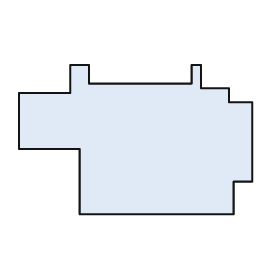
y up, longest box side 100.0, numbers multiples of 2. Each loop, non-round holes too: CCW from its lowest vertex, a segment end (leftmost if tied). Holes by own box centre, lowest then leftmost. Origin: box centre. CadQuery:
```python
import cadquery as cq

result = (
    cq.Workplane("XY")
    .moveTo(-24.0, -32.0)
    .lineTo(42.0, -32.0)
    .lineTo(42.0, -18.0)
    .lineTo(50.0, -18.0)
    .lineTo(50.0, 16.0)
    .lineTo(40.0, 16.0)
    .lineTo(40.0, 22.0)
    .lineTo(28.0, 22.0)
    .lineTo(28.0, 32.0)
    .lineTo(24.0, 32.0)
    .lineTo(24.0, 24.0)
    .lineTo(-20.0, 24.0)
    .lineTo(-20.0, 32.0)
    .lineTo(-28.0, 32.0)
    .lineTo(-28.0, 20.0)
    .lineTo(-50.0, 20.0)
    .lineTo(-50.0, -4.0)
    .lineTo(-24.0, -4.0)
    .close()
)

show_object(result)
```